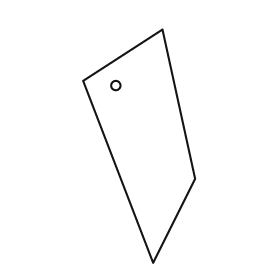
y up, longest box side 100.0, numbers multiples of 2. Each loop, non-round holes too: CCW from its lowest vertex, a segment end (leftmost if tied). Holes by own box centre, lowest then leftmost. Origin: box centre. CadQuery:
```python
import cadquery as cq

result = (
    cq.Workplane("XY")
    .moveTo(6.0, -50.0)
    .lineTo(24.0, -14.0)
    .lineTo(10.0, 50.0)
    .lineTo(-24.0, 28.0)
    .close()
    .moveTo(-10.0, 26.0)
    .circle(2.0)
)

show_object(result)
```